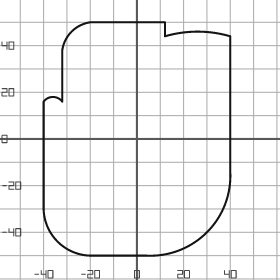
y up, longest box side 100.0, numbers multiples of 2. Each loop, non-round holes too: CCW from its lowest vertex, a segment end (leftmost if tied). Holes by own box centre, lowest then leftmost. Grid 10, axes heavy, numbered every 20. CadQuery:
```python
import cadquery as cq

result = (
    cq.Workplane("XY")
    .moveTo(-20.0, -50.0)
    .lineTo(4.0, -50.0)
    .threePointArc((30.0, -40.0), (40.0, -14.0))
    .lineTo(40.0, 44.0)
    .threePointArc((26.0, 46.0), (12.0, 44.0))
    .lineTo(12.0, 50.0)
    .lineTo(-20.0, 50.0)
    .threePointArc((-28.0, 46.0), (-32.0, 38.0))
    .lineTo(-32.0, 16.0)
    .threePointArc((-36.0, 18.0), (-40.0, 16.0))
    .lineTo(-40.0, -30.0)
    .threePointArc((-34.0, -44.0), (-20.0, -50.0))
    .close()
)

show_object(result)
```